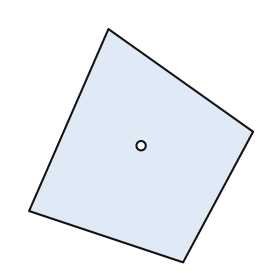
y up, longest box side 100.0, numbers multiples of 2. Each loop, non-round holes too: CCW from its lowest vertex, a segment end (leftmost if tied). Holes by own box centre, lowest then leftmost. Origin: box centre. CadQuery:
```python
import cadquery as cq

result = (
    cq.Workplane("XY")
    .moveTo(18.0, -50.0)
    .lineTo(48.0, 6.0)
    .lineTo(-14.0, 50.0)
    .lineTo(-48.0, -28.0)
    .close()
    .moveTo(0.0, 0.0)
    .circle(2.0)
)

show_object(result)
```